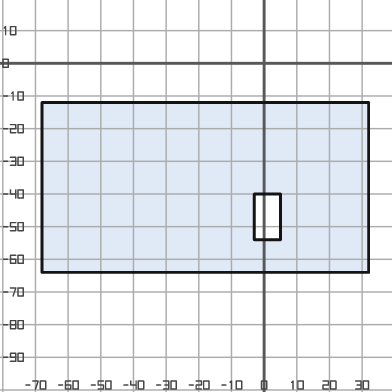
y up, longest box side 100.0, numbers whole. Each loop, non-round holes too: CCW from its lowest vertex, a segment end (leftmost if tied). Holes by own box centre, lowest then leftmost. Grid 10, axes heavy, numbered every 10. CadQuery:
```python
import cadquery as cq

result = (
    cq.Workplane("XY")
    .moveTo(-68.0, -64.0)
    .lineTo(32.0, -64.0)
    .lineTo(32.0, -12.0)
    .lineTo(-68.0, -12.0)
    .close()
    .moveTo(-3.0, -54.0)
    .lineTo(5.0, -54.0)
    .lineTo(5.0, -40.0)
    .lineTo(-3.0, -40.0)
    .close()
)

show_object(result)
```